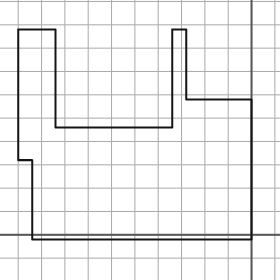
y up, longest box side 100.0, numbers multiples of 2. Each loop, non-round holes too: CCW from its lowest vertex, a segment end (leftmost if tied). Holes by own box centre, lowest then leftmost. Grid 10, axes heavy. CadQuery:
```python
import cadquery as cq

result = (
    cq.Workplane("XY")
    .moveTo(-94.0, -2.0)
    .lineTo(0.0, -2.0)
    .lineTo(0.0, 58.0)
    .lineTo(-28.0, 58.0)
    .lineTo(-28.0, 88.0)
    .lineTo(-34.0, 88.0)
    .lineTo(-34.0, 46.0)
    .lineTo(-84.0, 46.0)
    .lineTo(-84.0, 88.0)
    .lineTo(-100.0, 88.0)
    .lineTo(-100.0, 32.0)
    .lineTo(-94.0, 32.0)
    .close()
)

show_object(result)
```